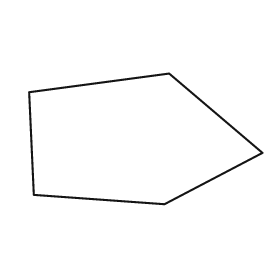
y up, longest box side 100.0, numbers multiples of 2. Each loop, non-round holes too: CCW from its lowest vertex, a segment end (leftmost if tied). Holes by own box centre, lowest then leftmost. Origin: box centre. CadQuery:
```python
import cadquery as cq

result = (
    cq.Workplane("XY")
    .moveTo(8.0, -28.0)
    .lineTo(50.0, -6.0)
    .lineTo(10.0, 28.0)
    .lineTo(-50.0, 20.0)
    .lineTo(-48.0, -24.0)
    .close()
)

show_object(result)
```